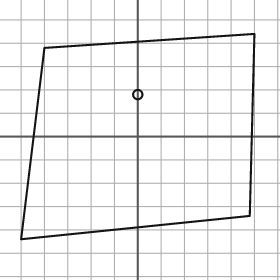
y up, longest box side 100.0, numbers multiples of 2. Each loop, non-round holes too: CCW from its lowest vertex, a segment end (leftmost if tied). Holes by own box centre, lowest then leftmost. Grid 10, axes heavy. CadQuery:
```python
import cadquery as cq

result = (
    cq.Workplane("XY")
    .moveTo(-50.0, -44.0)
    .lineTo(48.0, -34.0)
    .lineTo(50.0, 44.0)
    .lineTo(-40.0, 38.0)
    .close()
    .moveTo(0.0, 18.0)
    .circle(2.0)
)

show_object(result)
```